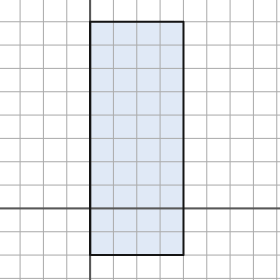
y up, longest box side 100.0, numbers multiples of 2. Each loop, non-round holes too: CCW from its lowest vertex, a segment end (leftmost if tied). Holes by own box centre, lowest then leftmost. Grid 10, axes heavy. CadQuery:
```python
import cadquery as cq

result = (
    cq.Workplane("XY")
    .moveTo(0.0, -20.0)
    .lineTo(40.0, -20.0)
    .lineTo(40.0, 80.0)
    .lineTo(0.0, 80.0)
    .close()
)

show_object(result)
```